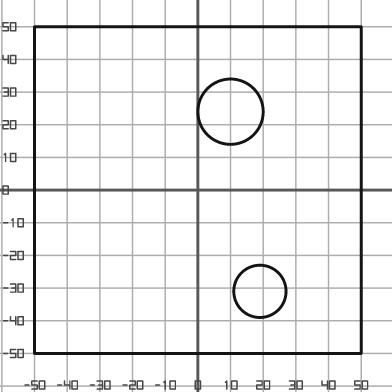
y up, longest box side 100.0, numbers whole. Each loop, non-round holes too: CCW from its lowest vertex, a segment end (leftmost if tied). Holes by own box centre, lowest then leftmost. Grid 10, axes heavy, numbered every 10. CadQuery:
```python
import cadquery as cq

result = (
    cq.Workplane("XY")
    .moveTo(-50.0, -50.0)
    .lineTo(50.0, -50.0)
    .lineTo(50.0, 50.0)
    .lineTo(-50.0, 50.0)
    .close()
    .moveTo(19.0, -31.0)
    .circle(8.0)
    .moveTo(10.0, 24.0)
    .circle(10.0)
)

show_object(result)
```